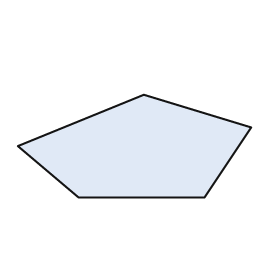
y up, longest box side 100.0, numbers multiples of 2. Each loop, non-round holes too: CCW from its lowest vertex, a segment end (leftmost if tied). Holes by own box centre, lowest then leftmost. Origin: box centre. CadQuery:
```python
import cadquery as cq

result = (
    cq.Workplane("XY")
    .moveTo(-24.0, -22.0)
    .lineTo(30.0, -22.0)
    .lineTo(50.0, 8.0)
    .lineTo(4.0, 22.0)
    .lineTo(-50.0, 0.0)
    .close()
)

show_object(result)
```